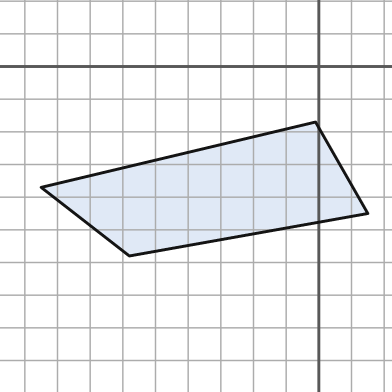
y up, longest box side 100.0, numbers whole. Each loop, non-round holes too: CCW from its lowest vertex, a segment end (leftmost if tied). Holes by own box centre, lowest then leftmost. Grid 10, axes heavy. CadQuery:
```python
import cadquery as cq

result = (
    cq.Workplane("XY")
    .moveTo(-58.0, -58.0)
    .lineTo(15.0, -45.0)
    .lineTo(-1.0, -17.0)
    .lineTo(-85.0, -37.0)
    .close()
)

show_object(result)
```